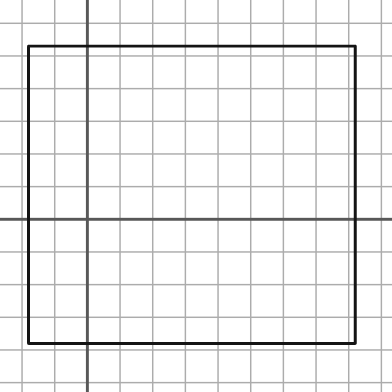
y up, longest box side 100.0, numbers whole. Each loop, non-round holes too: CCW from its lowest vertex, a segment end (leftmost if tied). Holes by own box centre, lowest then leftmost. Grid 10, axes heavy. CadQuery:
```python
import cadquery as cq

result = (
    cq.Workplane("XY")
    .moveTo(-18.0, -38.0)
    .lineTo(82.0, -38.0)
    .lineTo(82.0, 53.0)
    .lineTo(-18.0, 53.0)
    .close()
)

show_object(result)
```